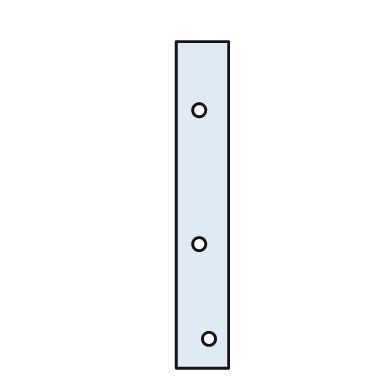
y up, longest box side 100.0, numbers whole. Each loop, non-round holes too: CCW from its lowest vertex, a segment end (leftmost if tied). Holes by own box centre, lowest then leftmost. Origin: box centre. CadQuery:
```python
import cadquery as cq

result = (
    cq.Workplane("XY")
    .moveTo(-8.0, -50.0)
    .lineTo(8.0, -50.0)
    .lineTo(8.0, 50.0)
    .lineTo(-8.0, 50.0)
    .close()
    .moveTo(2.0, -41.0)
    .circle(2.0)
    .moveTo(-1.0, -12.0)
    .circle(2.0)
    .moveTo(-1.0, 29.0)
    .circle(2.0)
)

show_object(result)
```